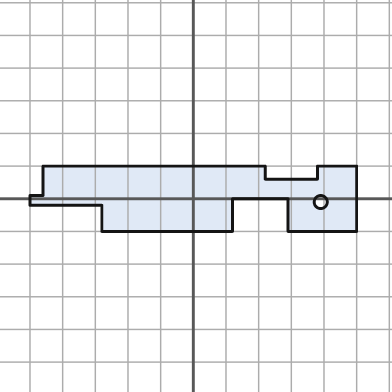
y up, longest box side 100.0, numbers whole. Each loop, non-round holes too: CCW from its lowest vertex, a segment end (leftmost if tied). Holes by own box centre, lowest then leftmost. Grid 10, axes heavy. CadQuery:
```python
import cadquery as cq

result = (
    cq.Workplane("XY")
    .moveTo(-28.0, -10.0)
    .lineTo(12.0, -10.0)
    .lineTo(12.0, 0.0)
    .lineTo(29.0, 0.0)
    .lineTo(29.0, -10.0)
    .lineTo(50.0, -10.0)
    .lineTo(50.0, 10.0)
    .lineTo(38.0, 10.0)
    .lineTo(38.0, 6.0)
    .lineTo(22.0, 6.0)
    .lineTo(22.0, 10.0)
    .lineTo(-46.0, 10.0)
    .lineTo(-46.0, 1.0)
    .lineTo(-50.0, 1.0)
    .lineTo(-50.0, -2.0)
    .lineTo(-28.0, -2.0)
    .close()
    .moveTo(39.0, -1.0)
    .circle(2.0)
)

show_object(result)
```